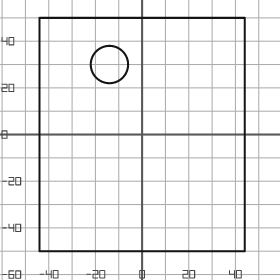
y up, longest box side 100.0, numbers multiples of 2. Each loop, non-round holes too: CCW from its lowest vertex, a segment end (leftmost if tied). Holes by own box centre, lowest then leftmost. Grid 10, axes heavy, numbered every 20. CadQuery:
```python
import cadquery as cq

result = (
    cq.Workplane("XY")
    .moveTo(-44.0, -50.0)
    .lineTo(44.0, -50.0)
    .lineTo(44.0, 50.0)
    .lineTo(-44.0, 50.0)
    .close()
    .moveTo(-14.0, 30.0)
    .circle(8.0)
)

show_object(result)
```